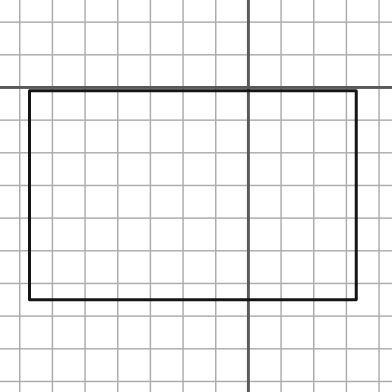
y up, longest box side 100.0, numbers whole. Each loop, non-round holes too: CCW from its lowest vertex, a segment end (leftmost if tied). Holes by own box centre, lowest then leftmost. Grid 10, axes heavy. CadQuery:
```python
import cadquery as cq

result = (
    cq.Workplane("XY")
    .moveTo(-67.0, -65.0)
    .lineTo(33.0, -65.0)
    .lineTo(33.0, -1.0)
    .lineTo(-67.0, -1.0)
    .close()
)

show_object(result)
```